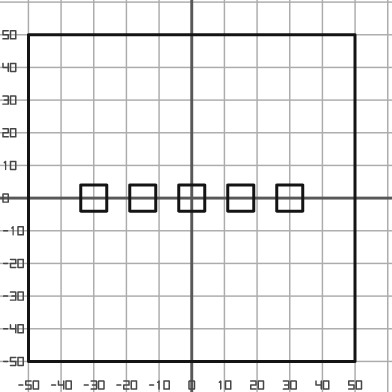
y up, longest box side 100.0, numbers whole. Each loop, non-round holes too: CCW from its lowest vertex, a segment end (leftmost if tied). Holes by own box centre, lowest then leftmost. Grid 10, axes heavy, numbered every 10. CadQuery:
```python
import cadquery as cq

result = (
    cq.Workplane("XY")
    .moveTo(-50.0, -50.0)
    .lineTo(50.0, -50.0)
    .lineTo(50.0, 50.0)
    .lineTo(-50.0, 50.0)
    .close()
    .moveTo(-34.0, -4.0)
    .lineTo(-26.0, -4.0)
    .lineTo(-26.0, 4.0)
    .lineTo(-34.0, 4.0)
    .close()
    .moveTo(-19.0, -4.0)
    .lineTo(-11.0, -4.0)
    .lineTo(-11.0, 4.0)
    .lineTo(-19.0, 4.0)
    .close()
    .moveTo(-4.0, -4.0)
    .lineTo(4.0, -4.0)
    .lineTo(4.0, 4.0)
    .lineTo(-4.0, 4.0)
    .close()
    .moveTo(11.0, -4.0)
    .lineTo(19.0, -4.0)
    .lineTo(19.0, 4.0)
    .lineTo(11.0, 4.0)
    .close()
    .moveTo(26.0, -4.0)
    .lineTo(34.0, -4.0)
    .lineTo(34.0, 4.0)
    .lineTo(26.0, 4.0)
    .close()
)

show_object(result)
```